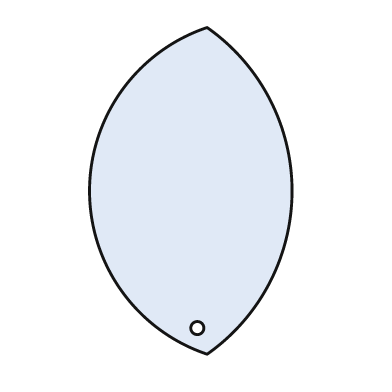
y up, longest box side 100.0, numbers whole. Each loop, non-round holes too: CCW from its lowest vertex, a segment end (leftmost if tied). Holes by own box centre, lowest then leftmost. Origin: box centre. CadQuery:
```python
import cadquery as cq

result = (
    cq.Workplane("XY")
    .moveTo(5.0, -50.0)
    .threePointArc((31.0, 0.0), (5.0, 50.0))
    .threePointArc((-31.0, 0.0), (5.0, -50.0))
    .close()
    .moveTo(2.0, -42.0)
    .circle(2.0)
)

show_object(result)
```